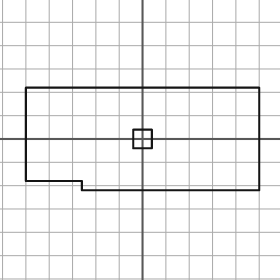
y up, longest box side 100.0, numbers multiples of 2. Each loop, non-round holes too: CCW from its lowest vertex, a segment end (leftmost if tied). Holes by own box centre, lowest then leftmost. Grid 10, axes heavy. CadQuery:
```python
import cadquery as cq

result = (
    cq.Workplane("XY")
    .moveTo(-26.0, -22.0)
    .lineTo(50.0, -22.0)
    .lineTo(50.0, 22.0)
    .lineTo(-50.0, 22.0)
    .lineTo(-50.0, -18.0)
    .lineTo(-26.0, -18.0)
    .close()
    .moveTo(-4.0, -4.0)
    .lineTo(4.0, -4.0)
    .lineTo(4.0, 4.0)
    .lineTo(-4.0, 4.0)
    .close()
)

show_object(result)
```